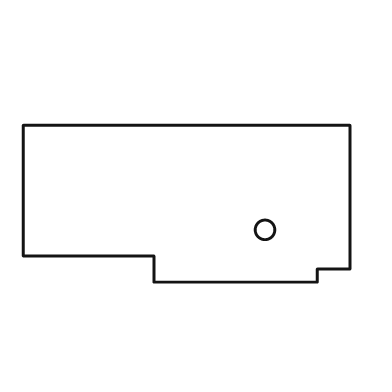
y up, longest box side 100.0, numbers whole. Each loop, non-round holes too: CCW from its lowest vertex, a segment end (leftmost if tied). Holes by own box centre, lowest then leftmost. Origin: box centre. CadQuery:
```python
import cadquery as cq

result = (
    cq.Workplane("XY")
    .moveTo(-10.0, -24.0)
    .lineTo(40.0, -24.0)
    .lineTo(40.0, -20.0)
    .lineTo(50.0, -20.0)
    .lineTo(50.0, 24.0)
    .lineTo(-50.0, 24.0)
    .lineTo(-50.0, -16.0)
    .lineTo(-10.0, -16.0)
    .close()
    .moveTo(24.0, -8.0)
    .circle(3.0)
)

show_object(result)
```